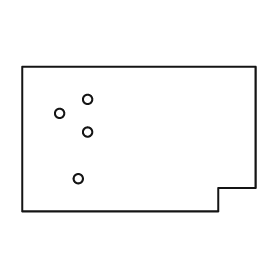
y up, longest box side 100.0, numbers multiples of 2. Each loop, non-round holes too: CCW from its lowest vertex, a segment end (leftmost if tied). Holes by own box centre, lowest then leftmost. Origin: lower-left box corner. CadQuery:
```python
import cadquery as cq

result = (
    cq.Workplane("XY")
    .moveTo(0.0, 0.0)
    .lineTo(84.0, 0.0)
    .lineTo(84.0, 10.0)
    .lineTo(100.0, 10.0)
    .lineTo(100.0, 62.0)
    .lineTo(0.0, 62.0)
    .close()
    .moveTo(24.0, 14.0)
    .circle(2.0)
    .moveTo(28.0, 34.0)
    .circle(2.0)
    .moveTo(16.0, 42.0)
    .circle(2.0)
    .moveTo(28.0, 48.0)
    .circle(2.0)
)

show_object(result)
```